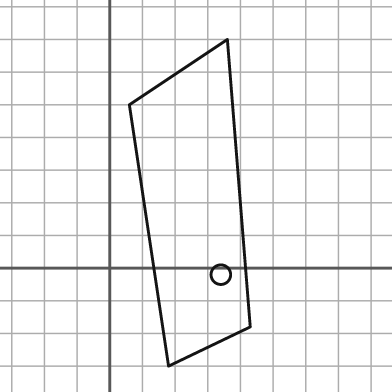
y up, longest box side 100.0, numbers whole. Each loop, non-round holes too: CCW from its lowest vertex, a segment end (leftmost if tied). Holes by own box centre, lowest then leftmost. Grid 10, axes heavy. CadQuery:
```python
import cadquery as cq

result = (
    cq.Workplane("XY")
    .moveTo(18.0, -30.0)
    .lineTo(43.0, -18.0)
    .lineTo(36.0, 70.0)
    .lineTo(6.0, 50.0)
    .close()
    .moveTo(34.0, -2.0)
    .circle(3.0)
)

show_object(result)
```